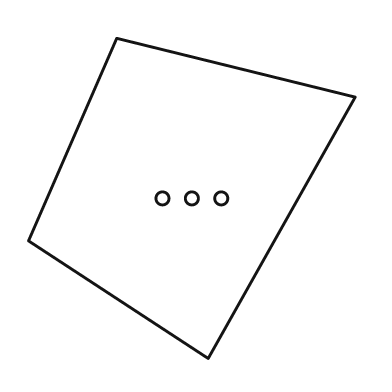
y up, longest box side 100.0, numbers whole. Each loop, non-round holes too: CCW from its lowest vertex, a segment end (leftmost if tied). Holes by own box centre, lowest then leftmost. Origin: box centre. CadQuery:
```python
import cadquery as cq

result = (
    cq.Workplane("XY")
    .moveTo(5.0, -49.0)
    .lineTo(50.0, 31.0)
    .lineTo(-23.0, 49.0)
    .lineTo(-50.0, -13.0)
    .close()
    .moveTo(-9.0, 0.0)
    .circle(2.0)
    .moveTo(0.0, 0.0)
    .circle(2.0)
    .moveTo(9.0, 0.0)
    .circle(2.0)
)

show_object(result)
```